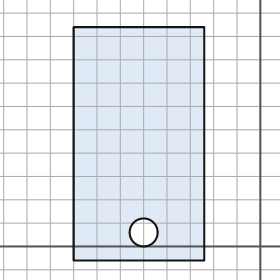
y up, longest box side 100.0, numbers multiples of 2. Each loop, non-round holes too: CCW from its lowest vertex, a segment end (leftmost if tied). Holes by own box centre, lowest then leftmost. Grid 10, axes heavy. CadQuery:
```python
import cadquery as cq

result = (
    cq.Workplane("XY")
    .moveTo(-80.0, -6.0)
    .lineTo(-24.0, -6.0)
    .lineTo(-24.0, 94.0)
    .lineTo(-80.0, 94.0)
    .close()
    .moveTo(-50.0, 6.0)
    .circle(6.0)
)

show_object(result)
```